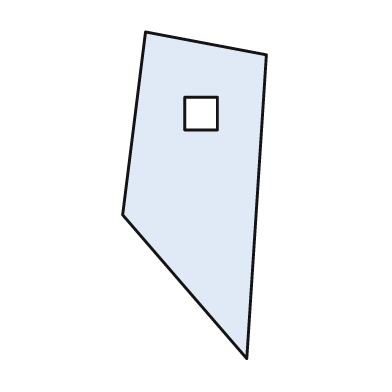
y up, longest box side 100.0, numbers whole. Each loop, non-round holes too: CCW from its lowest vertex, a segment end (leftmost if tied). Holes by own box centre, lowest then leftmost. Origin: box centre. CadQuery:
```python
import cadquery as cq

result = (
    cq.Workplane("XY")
    .moveTo(16.0, -50.0)
    .lineTo(22.0, 43.0)
    .lineTo(-15.0, 50.0)
    .lineTo(-22.0, -6.0)
    .close()
    .moveTo(-3.0, 20.0)
    .lineTo(7.0, 20.0)
    .lineTo(7.0, 30.0)
    .lineTo(-3.0, 30.0)
    .close()
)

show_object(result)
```